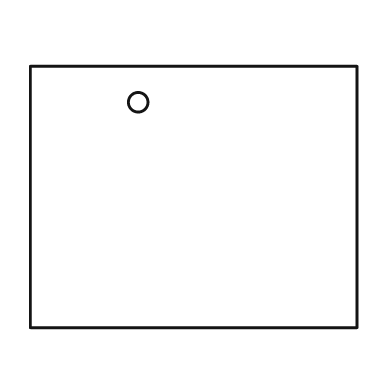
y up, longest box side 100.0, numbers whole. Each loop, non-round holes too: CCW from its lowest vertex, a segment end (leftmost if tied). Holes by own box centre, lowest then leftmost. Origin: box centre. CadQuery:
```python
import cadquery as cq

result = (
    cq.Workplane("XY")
    .moveTo(-50.0, -40.0)
    .lineTo(50.0, -40.0)
    .lineTo(50.0, 40.0)
    .lineTo(-50.0, 40.0)
    .close()
    .moveTo(-17.0, 29.0)
    .circle(3.0)
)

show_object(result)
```